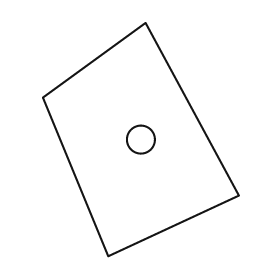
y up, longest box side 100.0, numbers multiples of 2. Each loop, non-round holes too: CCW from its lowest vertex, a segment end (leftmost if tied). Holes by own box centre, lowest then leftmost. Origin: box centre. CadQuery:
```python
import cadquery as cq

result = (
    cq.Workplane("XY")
    .moveTo(-14.0, -50.0)
    .lineTo(42.0, -24.0)
    .lineTo(2.0, 50.0)
    .lineTo(-42.0, 18.0)
    .close()
    .moveTo(0.0, 0.0)
    .circle(6.0)
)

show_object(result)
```